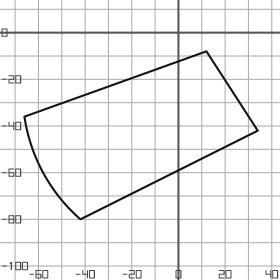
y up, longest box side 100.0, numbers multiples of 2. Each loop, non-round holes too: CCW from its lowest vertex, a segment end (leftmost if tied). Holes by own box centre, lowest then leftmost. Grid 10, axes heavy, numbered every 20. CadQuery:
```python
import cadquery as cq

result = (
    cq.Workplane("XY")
    .moveTo(-42.0, -80.0)
    .lineTo(34.0, -42.0)
    .lineTo(12.0, -8.0)
    .lineTo(-66.0, -36.0)
    .threePointArc((-58.0, -60.0), (-42.0, -80.0))
    .close()
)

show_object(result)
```